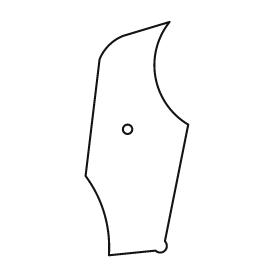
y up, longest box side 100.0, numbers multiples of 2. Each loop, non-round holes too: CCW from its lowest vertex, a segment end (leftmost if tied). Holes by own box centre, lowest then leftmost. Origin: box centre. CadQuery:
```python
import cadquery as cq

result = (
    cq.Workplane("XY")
    .moveTo(-12.0, -50.0)
    .lineTo(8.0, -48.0)
    .threePointArc((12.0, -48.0), (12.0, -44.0))
    .lineTo(22.0, 6.0)
    .threePointArc((8.0, 26.0), (14.0, 50.0))
    .lineTo(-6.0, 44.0)
    .threePointArc((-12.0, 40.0), (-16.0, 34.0))
    .lineTo(-22.0, -16.0)
    .threePointArc((-14.0, -32.0), (-12.0, -50.0))
    .close()
    .moveTo(-4.0, 4.0)
    .circle(2.0)
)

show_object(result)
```